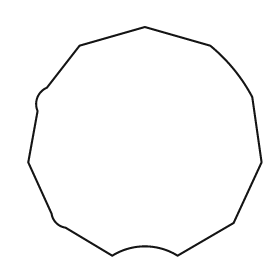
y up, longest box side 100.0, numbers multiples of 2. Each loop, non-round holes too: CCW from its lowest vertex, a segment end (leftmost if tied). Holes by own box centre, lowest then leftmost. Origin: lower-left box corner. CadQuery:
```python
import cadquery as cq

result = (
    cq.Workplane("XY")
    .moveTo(36.0, 0.0)
    .threePointArc((50.0, 4.0), (64.0, 0.0))
    .lineTo(88.0, 14.0)
    .lineTo(100.0, 40.0)
    .lineTo(96.0, 68.0)
    .threePointArc((88.0, 80.0), (78.0, 90.0))
    .lineTo(50.0, 98.0)
    .lineTo(22.0, 90.0)
    .lineTo(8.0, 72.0)
    .threePointArc((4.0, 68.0), (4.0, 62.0))
    .lineTo(0.0, 40.0)
    .lineTo(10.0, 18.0)
    .threePointArc((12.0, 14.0), (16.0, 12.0))
    .close()
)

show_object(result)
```